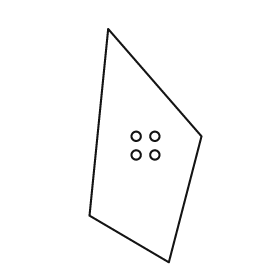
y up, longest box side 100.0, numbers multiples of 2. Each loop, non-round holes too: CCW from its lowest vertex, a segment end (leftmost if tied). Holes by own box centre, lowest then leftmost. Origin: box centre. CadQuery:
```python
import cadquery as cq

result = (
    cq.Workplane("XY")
    .moveTo(10.0, -50.0)
    .lineTo(24.0, 4.0)
    .lineTo(-16.0, 50.0)
    .lineTo(-24.0, -30.0)
    .close()
    .moveTo(-4.0, -4.0)
    .circle(2.0)
    .moveTo(4.0, -4.0)
    .circle(2.0)
    .moveTo(-4.0, 4.0)
    .circle(2.0)
    .moveTo(4.0, 4.0)
    .circle(2.0)
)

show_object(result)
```